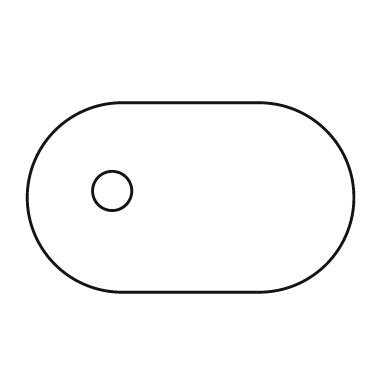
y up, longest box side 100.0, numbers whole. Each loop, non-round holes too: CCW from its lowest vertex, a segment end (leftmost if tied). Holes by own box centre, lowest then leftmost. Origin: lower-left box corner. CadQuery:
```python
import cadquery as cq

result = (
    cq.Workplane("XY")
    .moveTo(29.0, 0.0)
    .lineTo(71.0, 0.0)
    .threePointArc((100.0, 29.0), (71.0, 58.0))
    .lineTo(29.0, 58.0)
    .threePointArc((0.0, 29.0), (29.0, 0.0))
    .close()
    .moveTo(26.0, 31.0)
    .circle(6.0)
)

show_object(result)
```